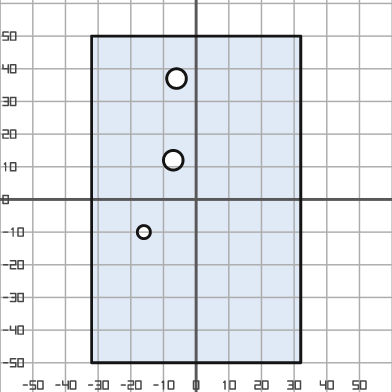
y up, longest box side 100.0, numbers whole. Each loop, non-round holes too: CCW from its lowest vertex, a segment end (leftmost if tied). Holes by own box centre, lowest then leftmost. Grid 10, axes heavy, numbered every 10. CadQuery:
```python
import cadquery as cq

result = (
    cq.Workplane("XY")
    .moveTo(-32.0, -50.0)
    .lineTo(32.0, -50.0)
    .lineTo(32.0, 50.0)
    .lineTo(-32.0, 50.0)
    .close()
    .moveTo(-16.0, -10.0)
    .circle(2.0)
    .moveTo(-7.0, 12.0)
    .circle(3.0)
    .moveTo(-6.0, 37.0)
    .circle(3.0)
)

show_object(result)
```